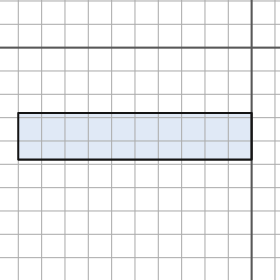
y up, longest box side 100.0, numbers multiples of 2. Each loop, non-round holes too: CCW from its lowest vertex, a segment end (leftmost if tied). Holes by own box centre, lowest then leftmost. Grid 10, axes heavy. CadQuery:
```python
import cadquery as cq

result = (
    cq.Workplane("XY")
    .moveTo(-100.0, -48.0)
    .lineTo(0.0, -48.0)
    .lineTo(0.0, -28.0)
    .lineTo(-100.0, -28.0)
    .close()
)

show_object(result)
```